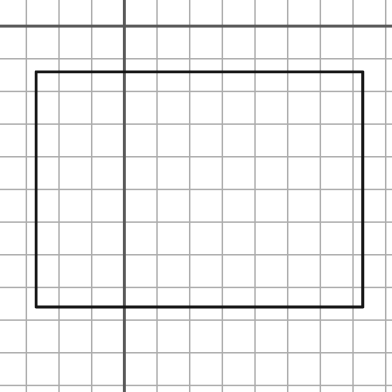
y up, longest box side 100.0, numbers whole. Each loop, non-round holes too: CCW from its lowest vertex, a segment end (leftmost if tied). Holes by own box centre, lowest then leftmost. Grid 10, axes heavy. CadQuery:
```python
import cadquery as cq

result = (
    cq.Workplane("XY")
    .moveTo(-27.0, -86.0)
    .lineTo(73.0, -86.0)
    .lineTo(73.0, -14.0)
    .lineTo(-27.0, -14.0)
    .close()
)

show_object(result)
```